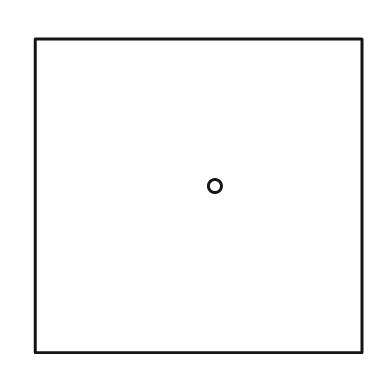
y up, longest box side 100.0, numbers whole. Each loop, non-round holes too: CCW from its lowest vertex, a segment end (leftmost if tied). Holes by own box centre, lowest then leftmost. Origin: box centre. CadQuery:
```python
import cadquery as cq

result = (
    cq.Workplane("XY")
    .moveTo(-50.0, -48.0)
    .lineTo(50.0, -48.0)
    .lineTo(50.0, 48.0)
    .lineTo(-50.0, 48.0)
    .close()
    .moveTo(5.0, 3.0)
    .circle(2.0)
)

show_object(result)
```